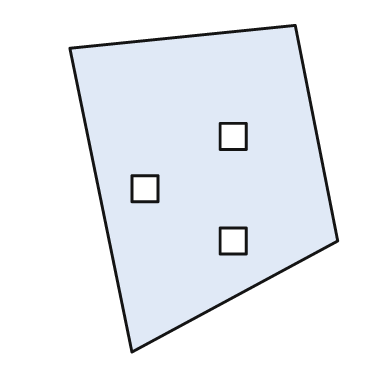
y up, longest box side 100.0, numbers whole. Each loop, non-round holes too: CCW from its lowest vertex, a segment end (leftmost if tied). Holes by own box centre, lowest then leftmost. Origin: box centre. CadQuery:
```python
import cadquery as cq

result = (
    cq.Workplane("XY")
    .moveTo(-22.0, -50.0)
    .lineTo(41.0, -16.0)
    .lineTo(28.0, 50.0)
    .lineTo(-41.0, 43.0)
    .close()
    .moveTo(5.0, -20.0)
    .lineTo(13.0, -20.0)
    .lineTo(13.0, -12.0)
    .lineTo(5.0, -12.0)
    .close()
    .moveTo(-22.0, -4.0)
    .lineTo(-14.0, -4.0)
    .lineTo(-14.0, 4.0)
    .lineTo(-22.0, 4.0)
    .close()
    .moveTo(5.0, 12.0)
    .lineTo(13.0, 12.0)
    .lineTo(13.0, 20.0)
    .lineTo(5.0, 20.0)
    .close()
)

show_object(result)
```